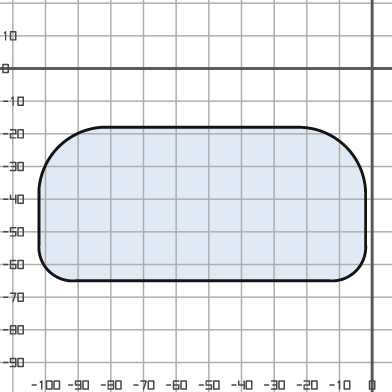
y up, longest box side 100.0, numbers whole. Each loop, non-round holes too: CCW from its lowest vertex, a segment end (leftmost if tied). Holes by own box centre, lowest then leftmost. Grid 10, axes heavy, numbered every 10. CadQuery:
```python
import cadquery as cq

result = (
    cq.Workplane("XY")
    .moveTo(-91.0, -65.0)
    .lineTo(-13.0, -65.0)
    .threePointArc((-5.0, -62.0), (-2.0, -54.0))
    .lineTo(-2.0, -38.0)
    .threePointArc((-8.0, -24.0), (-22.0, -18.0))
    .lineTo(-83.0, -18.0)
    .threePointArc((-96.0, -24.0), (-102.0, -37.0))
    .lineTo(-102.0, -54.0)
    .threePointArc((-99.0, -62.0), (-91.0, -65.0))
    .close()
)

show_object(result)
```